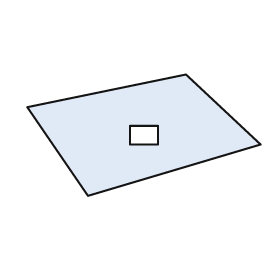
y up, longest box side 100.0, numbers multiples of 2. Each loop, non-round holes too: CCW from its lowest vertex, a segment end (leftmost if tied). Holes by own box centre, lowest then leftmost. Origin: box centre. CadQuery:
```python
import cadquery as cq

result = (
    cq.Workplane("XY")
    .moveTo(-24.0, -26.0)
    .lineTo(50.0, -4.0)
    .lineTo(18.0, 26.0)
    .lineTo(-50.0, 12.0)
    .close()
    .moveTo(-6.0, -4.0)
    .lineTo(6.0, -4.0)
    .lineTo(6.0, 4.0)
    .lineTo(-6.0, 4.0)
    .close()
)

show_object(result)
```